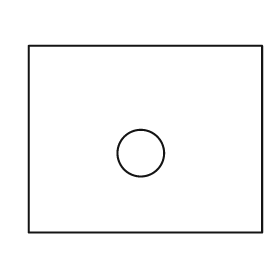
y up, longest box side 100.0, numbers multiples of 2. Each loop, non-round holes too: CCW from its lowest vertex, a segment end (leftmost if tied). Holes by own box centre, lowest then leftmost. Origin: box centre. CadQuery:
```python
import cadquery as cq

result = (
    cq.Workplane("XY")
    .moveTo(-50.0, -40.0)
    .lineTo(50.0, -40.0)
    .lineTo(50.0, 40.0)
    .lineTo(-50.0, 40.0)
    .close()
    .moveTo(-2.0, -6.0)
    .circle(10.0)
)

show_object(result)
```